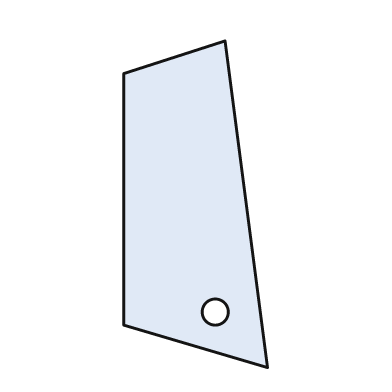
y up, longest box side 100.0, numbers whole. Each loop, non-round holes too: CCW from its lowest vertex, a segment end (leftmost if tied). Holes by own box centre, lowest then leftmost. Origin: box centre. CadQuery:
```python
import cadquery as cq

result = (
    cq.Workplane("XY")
    .moveTo(22.0, -50.0)
    .lineTo(9.0, 50.0)
    .lineTo(-22.0, 40.0)
    .lineTo(-22.0, -37.0)
    .close()
    .moveTo(6.0, -33.0)
    .circle(4.0)
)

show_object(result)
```